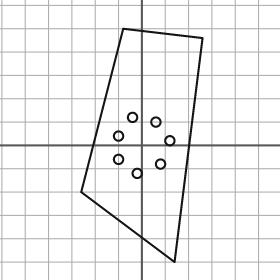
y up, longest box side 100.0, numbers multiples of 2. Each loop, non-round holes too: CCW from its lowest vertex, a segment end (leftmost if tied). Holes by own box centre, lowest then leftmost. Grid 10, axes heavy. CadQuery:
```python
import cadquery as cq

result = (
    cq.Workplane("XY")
    .moveTo(14.0, -50.0)
    .lineTo(26.0, 46.0)
    .lineTo(-8.0, 50.0)
    .lineTo(-26.0, -20.0)
    .close()
    .moveTo(-2.0, -12.0)
    .circle(2.0)
    .moveTo(8.0, -8.0)
    .circle(2.0)
    .moveTo(-10.0, -6.0)
    .circle(2.0)
    .moveTo(12.0, 2.0)
    .circle(2.0)
    .moveTo(-10.0, 4.0)
    .circle(2.0)
    .moveTo(6.0, 10.0)
    .circle(2.0)
    .moveTo(-4.0, 12.0)
    .circle(2.0)
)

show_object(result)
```